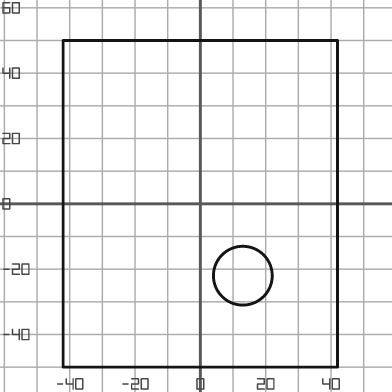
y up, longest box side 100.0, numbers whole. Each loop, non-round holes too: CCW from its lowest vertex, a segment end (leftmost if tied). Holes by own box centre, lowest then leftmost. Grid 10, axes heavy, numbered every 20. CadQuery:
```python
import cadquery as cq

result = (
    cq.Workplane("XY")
    .moveTo(-42.0, -50.0)
    .lineTo(42.0, -50.0)
    .lineTo(42.0, 50.0)
    .lineTo(-42.0, 50.0)
    .close()
    .moveTo(13.0, -22.0)
    .circle(9.0)
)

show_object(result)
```